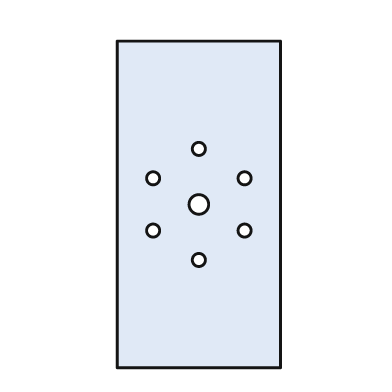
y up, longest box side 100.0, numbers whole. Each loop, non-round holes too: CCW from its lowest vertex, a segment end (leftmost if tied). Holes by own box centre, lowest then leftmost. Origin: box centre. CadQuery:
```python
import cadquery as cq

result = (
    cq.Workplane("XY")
    .moveTo(-25.0, -50.0)
    .lineTo(25.0, -50.0)
    .lineTo(25.0, 50.0)
    .lineTo(-25.0, 50.0)
    .close()
    .moveTo(0.0, -17.0)
    .circle(2.0)
    .moveTo(-14.0, -8.0)
    .circle(2.0)
    .moveTo(14.0, -8.0)
    .circle(2.0)
    .moveTo(0.0, 0.0)
    .circle(3.0)
    .moveTo(-14.0, 8.0)
    .circle(2.0)
    .moveTo(14.0, 8.0)
    .circle(2.0)
    .moveTo(0.0, 17.0)
    .circle(2.0)
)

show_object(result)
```